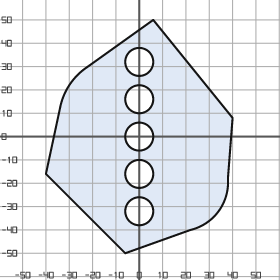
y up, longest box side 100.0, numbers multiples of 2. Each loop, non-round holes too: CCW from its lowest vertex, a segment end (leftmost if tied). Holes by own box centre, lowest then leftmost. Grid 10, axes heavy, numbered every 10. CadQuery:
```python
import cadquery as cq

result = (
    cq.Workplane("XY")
    .moveTo(-6.0, -50.0)
    .lineTo(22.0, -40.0)
    .threePointArc((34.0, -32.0), (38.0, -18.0))
    .lineTo(40.0, 8.0)
    .lineTo(6.0, 50.0)
    .lineTo(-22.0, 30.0)
    .threePointArc((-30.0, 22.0), (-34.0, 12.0))
    .lineTo(-40.0, -16.0)
    .close()
    .moveTo(0.0, -32.0)
    .circle(6.0)
    .moveTo(0.0, -16.0)
    .circle(6.0)
    .moveTo(0.0, 0.0)
    .circle(6.0)
    .moveTo(0.0, 16.0)
    .circle(6.0)
    .moveTo(0.0, 32.0)
    .circle(6.0)
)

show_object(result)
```